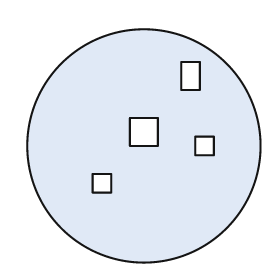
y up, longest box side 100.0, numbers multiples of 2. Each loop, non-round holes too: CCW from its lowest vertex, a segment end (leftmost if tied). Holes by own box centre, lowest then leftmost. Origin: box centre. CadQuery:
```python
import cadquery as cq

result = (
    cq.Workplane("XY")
    .moveTo(0.0, 0.0)
    .circle(50.0)
    .moveTo(-22.0, -20.0)
    .lineTo(-14.0, -20.0)
    .lineTo(-14.0, -12.0)
    .lineTo(-22.0, -12.0)
    .close()
    .moveTo(22.0, -4.0)
    .lineTo(30.0, -4.0)
    .lineTo(30.0, 4.0)
    .lineTo(22.0, 4.0)
    .close()
    .moveTo(-6.0, 0.0)
    .lineTo(6.0, 0.0)
    .lineTo(6.0, 12.0)
    .lineTo(-6.0, 12.0)
    .close()
    .moveTo(16.0, 24.0)
    .lineTo(24.0, 24.0)
    .lineTo(24.0, 36.0)
    .lineTo(16.0, 36.0)
    .close()
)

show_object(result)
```